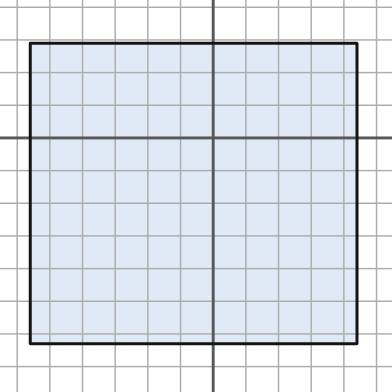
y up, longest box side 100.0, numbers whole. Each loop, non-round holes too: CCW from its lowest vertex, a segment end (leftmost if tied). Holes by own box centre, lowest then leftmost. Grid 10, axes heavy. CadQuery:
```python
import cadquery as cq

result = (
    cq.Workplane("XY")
    .moveTo(-56.0, -63.0)
    .lineTo(44.0, -63.0)
    .lineTo(44.0, 29.0)
    .lineTo(-56.0, 29.0)
    .close()
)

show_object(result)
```